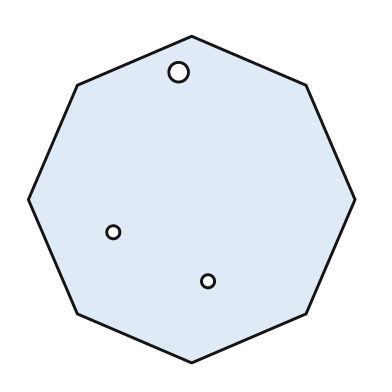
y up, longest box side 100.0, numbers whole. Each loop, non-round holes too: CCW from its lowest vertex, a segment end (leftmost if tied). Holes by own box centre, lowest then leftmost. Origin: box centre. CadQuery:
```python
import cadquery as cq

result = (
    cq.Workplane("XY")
    .moveTo(0.0, -50.0)
    .lineTo(35.0, -35.0)
    .lineTo(50.0, 0.0)
    .lineTo(35.0, 35.0)
    .lineTo(0.0, 50.0)
    .lineTo(-35.0, 35.0)
    .lineTo(-50.0, 0.0)
    .lineTo(-35.0, -35.0)
    .close()
    .moveTo(5.0, -25.0)
    .circle(2.0)
    .moveTo(-24.0, -10.0)
    .circle(2.0)
    .moveTo(-4.0, 39.0)
    .circle(3.0)
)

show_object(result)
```